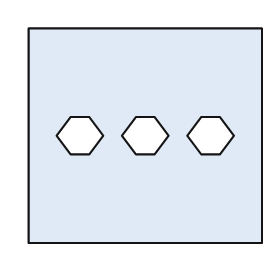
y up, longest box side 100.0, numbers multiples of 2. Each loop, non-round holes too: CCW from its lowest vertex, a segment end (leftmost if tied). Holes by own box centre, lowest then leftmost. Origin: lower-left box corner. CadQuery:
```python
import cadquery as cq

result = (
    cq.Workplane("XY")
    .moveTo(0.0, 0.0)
    .lineTo(100.0, 0.0)
    .lineTo(100.0, 92.0)
    .lineTo(0.0, 92.0)
    .close()
    .moveTo(18.0, 38.0)
    .lineTo(26.0, 38.0)
    .lineTo(32.0, 46.0)
    .lineTo(26.0, 54.0)
    .lineTo(18.0, 54.0)
    .lineTo(12.0, 46.0)
    .close()
    .moveTo(46.0, 38.0)
    .lineTo(54.0, 38.0)
    .lineTo(60.0, 46.0)
    .lineTo(54.0, 54.0)
    .lineTo(46.0, 54.0)
    .lineTo(40.0, 46.0)
    .close()
    .moveTo(74.0, 38.0)
    .lineTo(82.0, 38.0)
    .lineTo(88.0, 46.0)
    .lineTo(82.0, 54.0)
    .lineTo(74.0, 54.0)
    .lineTo(68.0, 46.0)
    .close()
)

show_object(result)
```